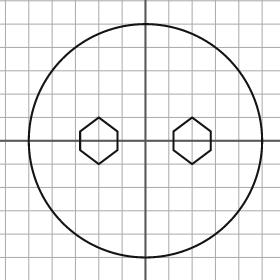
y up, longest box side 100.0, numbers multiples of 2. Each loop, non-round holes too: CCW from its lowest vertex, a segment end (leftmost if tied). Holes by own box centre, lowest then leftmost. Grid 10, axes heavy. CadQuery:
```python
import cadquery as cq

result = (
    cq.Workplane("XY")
    .moveTo(0.0, 0.0)
    .circle(50.0)
    .moveTo(-20.0, -10.0)
    .lineTo(-12.0, -4.0)
    .lineTo(-12.0, 4.0)
    .lineTo(-20.0, 10.0)
    .lineTo(-28.0, 4.0)
    .lineTo(-28.0, -4.0)
    .close()
    .moveTo(20.0, -10.0)
    .lineTo(28.0, -4.0)
    .lineTo(28.0, 4.0)
    .lineTo(20.0, 10.0)
    .lineTo(12.0, 4.0)
    .lineTo(12.0, -4.0)
    .close()
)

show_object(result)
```